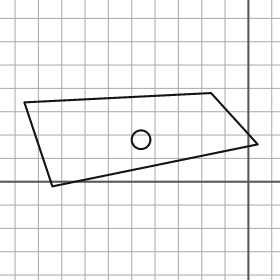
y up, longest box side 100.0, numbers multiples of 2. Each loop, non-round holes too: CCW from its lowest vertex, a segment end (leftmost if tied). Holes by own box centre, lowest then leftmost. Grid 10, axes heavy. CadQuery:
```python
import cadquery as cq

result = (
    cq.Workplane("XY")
    .moveTo(-84.0, -2.0)
    .lineTo(4.0, 16.0)
    .lineTo(-16.0, 38.0)
    .lineTo(-96.0, 34.0)
    .close()
    .moveTo(-46.0, 18.0)
    .circle(4.0)
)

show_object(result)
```